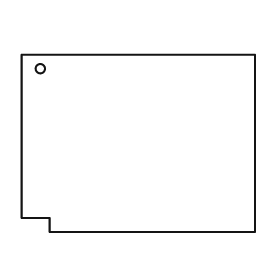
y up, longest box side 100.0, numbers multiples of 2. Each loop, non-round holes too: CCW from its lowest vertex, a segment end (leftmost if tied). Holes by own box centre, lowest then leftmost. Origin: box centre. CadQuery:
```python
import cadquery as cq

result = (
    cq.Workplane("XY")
    .moveTo(-38.0, -38.0)
    .lineTo(50.0, -38.0)
    .lineTo(50.0, 38.0)
    .lineTo(-50.0, 38.0)
    .lineTo(-50.0, -32.0)
    .lineTo(-38.0, -32.0)
    .close()
    .moveTo(-42.0, 32.0)
    .circle(2.0)
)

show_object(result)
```